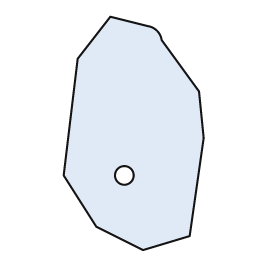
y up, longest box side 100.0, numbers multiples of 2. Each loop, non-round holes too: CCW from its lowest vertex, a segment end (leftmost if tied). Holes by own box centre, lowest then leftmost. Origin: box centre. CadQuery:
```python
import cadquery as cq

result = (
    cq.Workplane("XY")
    .moveTo(4.0, -50.0)
    .lineTo(24.0, -44.0)
    .lineTo(30.0, -2.0)
    .lineTo(28.0, 18.0)
    .lineTo(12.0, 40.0)
    .threePointArc((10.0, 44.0), (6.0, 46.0))
    .lineTo(-10.0, 50.0)
    .lineTo(-24.0, 32.0)
    .lineTo(-30.0, -18.0)
    .lineTo(-16.0, -40.0)
    .close()
    .moveTo(-4.0, -18.0)
    .circle(4.0)
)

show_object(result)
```